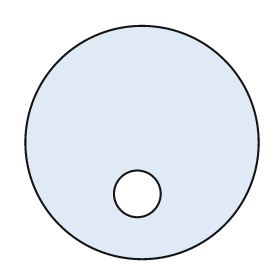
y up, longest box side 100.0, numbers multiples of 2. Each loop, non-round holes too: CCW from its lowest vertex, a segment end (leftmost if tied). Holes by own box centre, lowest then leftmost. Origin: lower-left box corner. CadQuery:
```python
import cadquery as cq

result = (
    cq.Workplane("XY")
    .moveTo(50.0, 50.0)
    .circle(50.0)
    .moveTo(48.0, 28.0)
    .circle(10.0)
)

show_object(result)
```